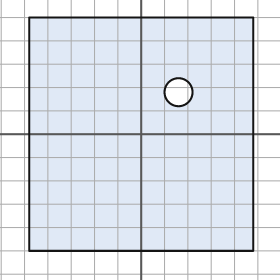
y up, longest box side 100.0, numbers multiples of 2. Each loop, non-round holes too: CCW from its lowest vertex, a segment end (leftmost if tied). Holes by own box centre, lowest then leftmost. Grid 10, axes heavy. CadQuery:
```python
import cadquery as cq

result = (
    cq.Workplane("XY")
    .moveTo(-48.0, -50.0)
    .lineTo(48.0, -50.0)
    .lineTo(48.0, 50.0)
    .lineTo(-48.0, 50.0)
    .close()
    .moveTo(16.0, 18.0)
    .circle(6.0)
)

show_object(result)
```